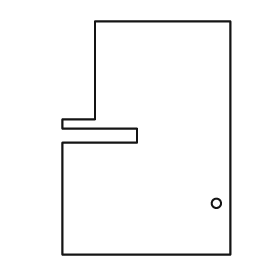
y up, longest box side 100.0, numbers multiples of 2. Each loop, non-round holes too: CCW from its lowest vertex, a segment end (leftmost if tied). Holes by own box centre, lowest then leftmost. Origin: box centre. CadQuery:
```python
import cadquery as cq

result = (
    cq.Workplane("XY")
    .moveTo(-36.0, -50.0)
    .lineTo(36.0, -50.0)
    .lineTo(36.0, 50.0)
    .lineTo(-22.0, 50.0)
    .lineTo(-22.0, 8.0)
    .lineTo(-36.0, 8.0)
    .lineTo(-36.0, 4.0)
    .lineTo(-4.0, 4.0)
    .lineTo(-4.0, -2.0)
    .lineTo(-36.0, -2.0)
    .close()
    .moveTo(30.0, -28.0)
    .circle(2.0)
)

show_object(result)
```